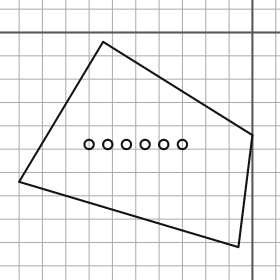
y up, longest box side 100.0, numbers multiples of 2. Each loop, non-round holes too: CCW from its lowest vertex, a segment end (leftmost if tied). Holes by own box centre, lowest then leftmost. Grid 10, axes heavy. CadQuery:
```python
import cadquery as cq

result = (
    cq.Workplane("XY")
    .moveTo(-6.0, -92.0)
    .lineTo(0.0, -44.0)
    .lineTo(-64.0, -4.0)
    .lineTo(-100.0, -64.0)
    .close()
    .moveTo(-70.0, -48.0)
    .circle(2.0)
    .moveTo(-62.0, -48.0)
    .circle(2.0)
    .moveTo(-54.0, -48.0)
    .circle(2.0)
    .moveTo(-46.0, -48.0)
    .circle(2.0)
    .moveTo(-38.0, -48.0)
    .circle(2.0)
    .moveTo(-30.0, -48.0)
    .circle(2.0)
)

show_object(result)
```